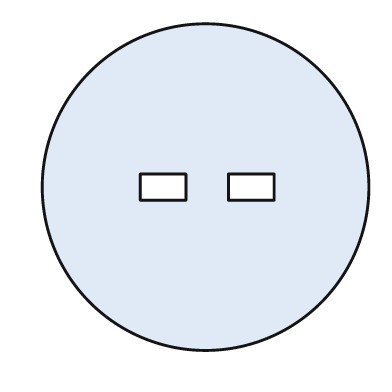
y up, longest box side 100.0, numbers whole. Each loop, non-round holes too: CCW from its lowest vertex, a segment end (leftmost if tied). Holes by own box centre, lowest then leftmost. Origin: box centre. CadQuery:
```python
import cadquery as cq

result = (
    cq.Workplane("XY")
    .moveTo(0.0, 0.0)
    .circle(50.0)
    .moveTo(-20.0, -4.0)
    .lineTo(-6.0, -4.0)
    .lineTo(-6.0, 4.0)
    .lineTo(-20.0, 4.0)
    .close()
    .moveTo(7.0, -4.0)
    .lineTo(21.0, -4.0)
    .lineTo(21.0, 4.0)
    .lineTo(7.0, 4.0)
    .close()
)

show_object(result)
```